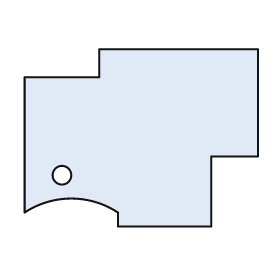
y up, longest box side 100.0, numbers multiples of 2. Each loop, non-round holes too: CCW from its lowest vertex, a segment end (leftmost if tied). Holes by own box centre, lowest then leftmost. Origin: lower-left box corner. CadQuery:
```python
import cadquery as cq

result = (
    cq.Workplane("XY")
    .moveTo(40.0, 0.0)
    .lineTo(80.0, 0.0)
    .lineTo(80.0, 30.0)
    .lineTo(100.0, 30.0)
    .lineTo(100.0, 76.0)
    .lineTo(32.0, 76.0)
    .lineTo(32.0, 64.0)
    .lineTo(0.0, 64.0)
    .lineTo(0.0, 6.0)
    .threePointArc((20.0, 12.0), (40.0, 6.0))
    .close()
    .moveTo(16.0, 22.0)
    .circle(4.0)
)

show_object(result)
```